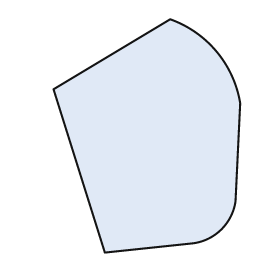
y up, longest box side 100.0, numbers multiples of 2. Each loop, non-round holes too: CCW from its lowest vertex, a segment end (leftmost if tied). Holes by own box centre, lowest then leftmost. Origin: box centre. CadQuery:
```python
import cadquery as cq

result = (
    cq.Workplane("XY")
    .moveTo(-18.0, -50.0)
    .lineTo(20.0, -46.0)
    .threePointArc((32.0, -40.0), (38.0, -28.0))
    .lineTo(40.0, 14.0)
    .threePointArc((30.0, 36.0), (10.0, 50.0))
    .lineTo(-40.0, 20.0)
    .close()
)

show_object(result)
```